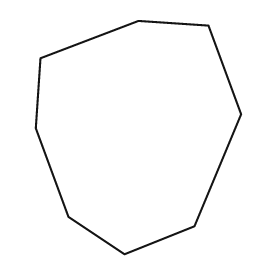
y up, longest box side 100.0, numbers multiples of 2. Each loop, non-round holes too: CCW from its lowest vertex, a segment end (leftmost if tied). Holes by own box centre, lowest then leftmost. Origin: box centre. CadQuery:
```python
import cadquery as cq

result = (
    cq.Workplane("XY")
    .moveTo(-6.0, -50.0)
    .lineTo(24.0, -38.0)
    .lineTo(44.0, 10.0)
    .lineTo(30.0, 48.0)
    .lineTo(0.0, 50.0)
    .lineTo(-42.0, 34.0)
    .lineTo(-44.0, 4.0)
    .lineTo(-30.0, -34.0)
    .close()
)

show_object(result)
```